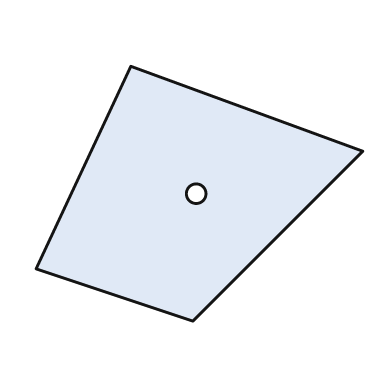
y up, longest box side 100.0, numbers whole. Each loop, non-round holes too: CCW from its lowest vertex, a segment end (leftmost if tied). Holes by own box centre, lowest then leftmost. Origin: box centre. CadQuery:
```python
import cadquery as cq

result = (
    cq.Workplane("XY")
    .moveTo(-2.0, -39.0)
    .lineTo(50.0, 13.0)
    .lineTo(-21.0, 39.0)
    .lineTo(-50.0, -23.0)
    .close()
    .moveTo(-1.0, 0.0)
    .circle(3.0)
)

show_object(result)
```